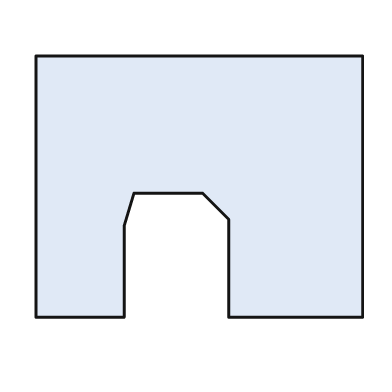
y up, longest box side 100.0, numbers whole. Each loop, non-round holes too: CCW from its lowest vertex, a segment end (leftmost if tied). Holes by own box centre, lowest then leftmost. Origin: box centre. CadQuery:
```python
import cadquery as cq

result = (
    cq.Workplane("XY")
    .moveTo(-50.0, -40.0)
    .lineTo(-23.0, -40.0)
    .lineTo(-23.0, -12.0)
    .lineTo(-20.0, -2.0)
    .lineTo(1.0, -2.0)
    .lineTo(9.0, -10.0)
    .lineTo(9.0, -40.0)
    .lineTo(50.0, -40.0)
    .lineTo(50.0, 40.0)
    .lineTo(-50.0, 40.0)
    .close()
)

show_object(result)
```